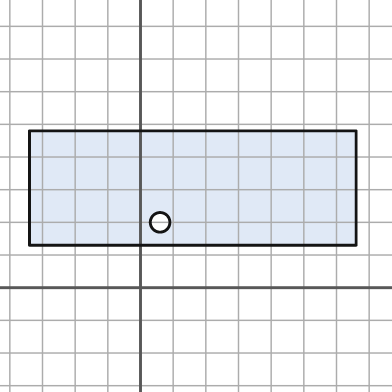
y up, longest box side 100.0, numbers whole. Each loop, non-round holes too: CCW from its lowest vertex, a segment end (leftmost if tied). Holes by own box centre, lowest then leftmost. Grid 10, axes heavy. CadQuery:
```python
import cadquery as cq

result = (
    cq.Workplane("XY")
    .moveTo(-34.0, 13.0)
    .lineTo(66.0, 13.0)
    .lineTo(66.0, 48.0)
    .lineTo(-34.0, 48.0)
    .close()
    .moveTo(6.0, 20.0)
    .circle(3.0)
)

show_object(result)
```